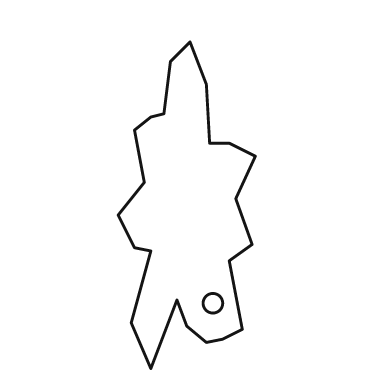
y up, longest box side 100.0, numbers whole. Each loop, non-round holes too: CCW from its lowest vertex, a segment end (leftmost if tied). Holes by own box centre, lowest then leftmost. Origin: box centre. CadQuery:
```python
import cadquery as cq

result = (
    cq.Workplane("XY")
    .moveTo(-11.0, -50.0)
    .lineTo(-3.0, -29.0)
    .lineTo(0.0, -37.0)
    .lineTo(6.0, -42.0)
    .lineTo(11.0, -41.0)
    .lineTo(17.0, -38.0)
    .lineTo(13.0, -17.0)
    .lineTo(20.0, -12.0)
    .lineTo(15.0, 2.0)
    .lineTo(21.0, 15.0)
    .lineTo(13.0, 19.0)
    .lineTo(7.0, 19.0)
    .lineTo(6.0, 37.0)
    .lineTo(1.0, 50.0)
    .lineTo(-5.0, 44.0)
    .lineTo(-7.0, 28.0)
    .lineTo(-11.0, 27.0)
    .lineTo(-16.0, 23.0)
    .lineTo(-13.0, 7.0)
    .lineTo(-21.0, -3.0)
    .lineTo(-16.0, -13.0)
    .lineTo(-11.0, -14.0)
    .lineTo(-17.0, -36.0)
    .close()
    .moveTo(8.0, -30.0)
    .circle(3.0)
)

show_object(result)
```